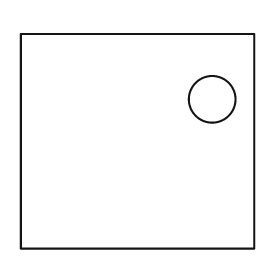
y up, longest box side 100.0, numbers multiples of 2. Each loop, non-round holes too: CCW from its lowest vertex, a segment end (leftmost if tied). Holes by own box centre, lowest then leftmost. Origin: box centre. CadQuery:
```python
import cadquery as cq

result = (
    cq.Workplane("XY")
    .moveTo(-50.0, -46.0)
    .lineTo(50.0, -46.0)
    .lineTo(50.0, 46.0)
    .lineTo(-50.0, 46.0)
    .close()
    .moveTo(32.0, 18.0)
    .circle(10.0)
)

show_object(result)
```